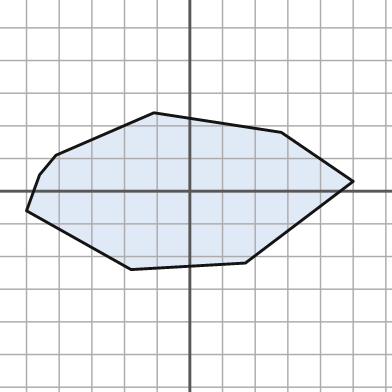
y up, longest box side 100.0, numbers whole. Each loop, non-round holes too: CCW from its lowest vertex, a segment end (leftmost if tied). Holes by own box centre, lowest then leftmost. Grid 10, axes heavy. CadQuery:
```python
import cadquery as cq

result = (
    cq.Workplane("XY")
    .moveTo(-18.0, -24.0)
    .lineTo(17.0, -22.0)
    .lineTo(50.0, 3.0)
    .lineTo(28.0, 18.0)
    .lineTo(-11.0, 24.0)
    .lineTo(-41.0, 11.0)
    .lineTo(-46.0, 5.0)
    .lineTo(-50.0, -6.0)
    .close()
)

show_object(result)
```